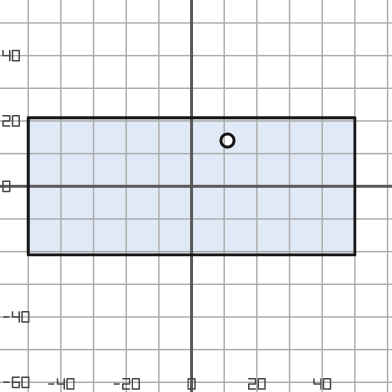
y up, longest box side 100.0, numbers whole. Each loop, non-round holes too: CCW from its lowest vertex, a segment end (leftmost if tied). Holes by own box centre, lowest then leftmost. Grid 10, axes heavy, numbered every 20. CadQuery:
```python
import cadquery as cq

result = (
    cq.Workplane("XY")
    .moveTo(-50.0, -21.0)
    .lineTo(50.0, -21.0)
    .lineTo(50.0, 21.0)
    .lineTo(-50.0, 21.0)
    .close()
    .moveTo(11.0, 14.0)
    .circle(2.0)
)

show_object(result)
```